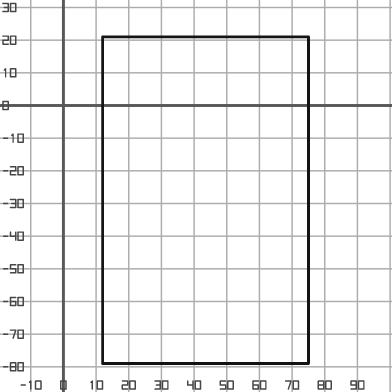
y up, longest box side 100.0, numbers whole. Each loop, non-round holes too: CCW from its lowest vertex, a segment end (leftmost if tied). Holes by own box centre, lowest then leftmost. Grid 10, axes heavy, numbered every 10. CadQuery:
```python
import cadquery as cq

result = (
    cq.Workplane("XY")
    .moveTo(12.0, -79.0)
    .lineTo(75.0, -79.0)
    .lineTo(75.0, 21.0)
    .lineTo(12.0, 21.0)
    .close()
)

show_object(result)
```